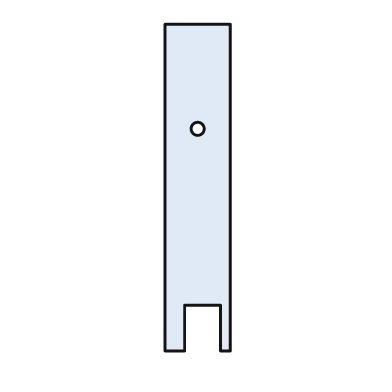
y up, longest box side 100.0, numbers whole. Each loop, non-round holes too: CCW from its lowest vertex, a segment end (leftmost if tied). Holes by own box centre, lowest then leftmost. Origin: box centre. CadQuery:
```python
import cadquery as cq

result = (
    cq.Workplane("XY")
    .moveTo(-10.0, -50.0)
    .lineTo(-4.0, -50.0)
    .lineTo(-4.0, -36.0)
    .lineTo(7.0, -36.0)
    .lineTo(7.0, -50.0)
    .lineTo(10.0, -50.0)
    .lineTo(10.0, 50.0)
    .lineTo(-10.0, 50.0)
    .close()
    .moveTo(0.0, 18.0)
    .circle(2.0)
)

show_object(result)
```